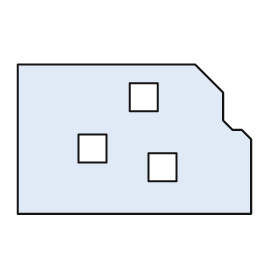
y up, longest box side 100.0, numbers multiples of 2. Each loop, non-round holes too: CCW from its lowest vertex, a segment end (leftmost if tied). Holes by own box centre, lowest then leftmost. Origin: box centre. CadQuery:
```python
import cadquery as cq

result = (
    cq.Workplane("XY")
    .moveTo(-50.0, -32.0)
    .lineTo(50.0, -32.0)
    .lineTo(50.0, 0.0)
    .lineTo(46.0, 4.0)
    .lineTo(42.0, 4.0)
    .lineTo(38.0, 8.0)
    .lineTo(38.0, 20.0)
    .lineTo(26.0, 32.0)
    .lineTo(-50.0, 32.0)
    .close()
    .moveTo(6.0, -18.0)
    .lineTo(18.0, -18.0)
    .lineTo(18.0, -6.0)
    .lineTo(6.0, -6.0)
    .close()
    .moveTo(-24.0, -10.0)
    .lineTo(-12.0, -10.0)
    .lineTo(-12.0, 2.0)
    .lineTo(-24.0, 2.0)
    .close()
    .moveTo(-2.0, 12.0)
    .lineTo(10.0, 12.0)
    .lineTo(10.0, 24.0)
    .lineTo(-2.0, 24.0)
    .close()
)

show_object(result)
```